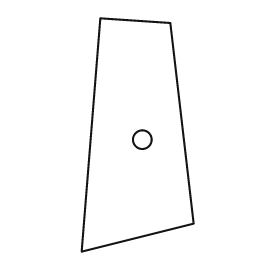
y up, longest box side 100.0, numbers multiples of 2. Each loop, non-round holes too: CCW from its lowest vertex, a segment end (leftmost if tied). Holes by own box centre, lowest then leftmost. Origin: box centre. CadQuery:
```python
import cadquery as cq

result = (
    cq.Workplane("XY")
    .moveTo(-24.0, -50.0)
    .lineTo(24.0, -38.0)
    .lineTo(14.0, 48.0)
    .lineTo(-16.0, 50.0)
    .close()
    .moveTo(2.0, -2.0)
    .circle(4.0)
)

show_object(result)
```